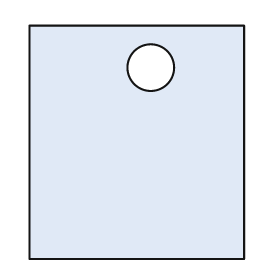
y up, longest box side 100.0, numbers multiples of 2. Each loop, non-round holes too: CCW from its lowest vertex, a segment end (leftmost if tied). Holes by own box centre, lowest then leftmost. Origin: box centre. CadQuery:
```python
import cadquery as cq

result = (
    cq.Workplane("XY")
    .moveTo(-46.0, -50.0)
    .lineTo(46.0, -50.0)
    .lineTo(46.0, 50.0)
    .lineTo(-46.0, 50.0)
    .close()
    .moveTo(6.0, 32.0)
    .circle(10.0)
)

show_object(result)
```